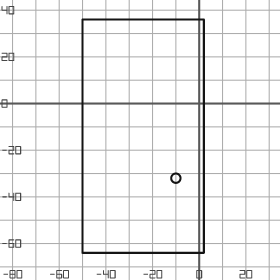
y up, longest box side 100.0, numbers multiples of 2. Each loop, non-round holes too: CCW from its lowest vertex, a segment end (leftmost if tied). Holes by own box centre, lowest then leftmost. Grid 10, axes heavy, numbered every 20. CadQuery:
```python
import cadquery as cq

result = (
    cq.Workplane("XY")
    .moveTo(-50.0, -64.0)
    .lineTo(2.0, -64.0)
    .lineTo(2.0, 36.0)
    .lineTo(-50.0, 36.0)
    .close()
    .moveTo(-10.0, -32.0)
    .circle(2.0)
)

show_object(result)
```